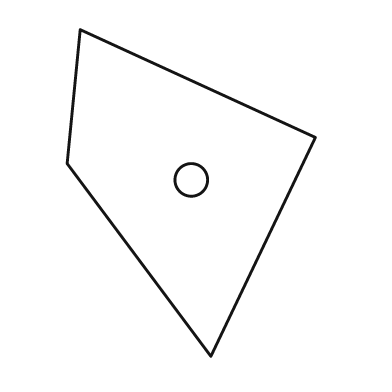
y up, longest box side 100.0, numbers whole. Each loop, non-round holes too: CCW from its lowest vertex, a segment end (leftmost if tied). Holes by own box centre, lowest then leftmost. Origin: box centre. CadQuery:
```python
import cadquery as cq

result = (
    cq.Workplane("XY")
    .moveTo(6.0, -50.0)
    .lineTo(38.0, 17.0)
    .lineTo(-34.0, 50.0)
    .lineTo(-38.0, 9.0)
    .close()
    .moveTo(0.0, 4.0)
    .circle(5.0)
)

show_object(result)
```